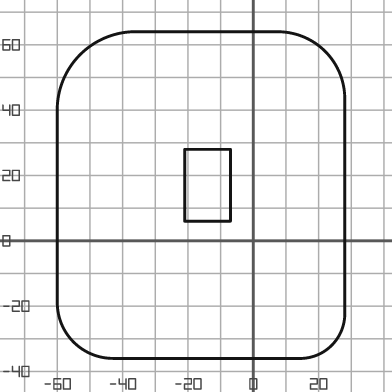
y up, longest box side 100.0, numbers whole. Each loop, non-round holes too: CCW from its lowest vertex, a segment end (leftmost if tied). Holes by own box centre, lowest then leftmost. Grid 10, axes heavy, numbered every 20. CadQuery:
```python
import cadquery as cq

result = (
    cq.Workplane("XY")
    .moveTo(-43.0, -36.0)
    .lineTo(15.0, -36.0)
    .threePointArc((24.0, -32.0), (28.0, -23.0))
    .lineTo(28.0, 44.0)
    .threePointArc((22.0, 58.0), (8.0, 64.0))
    .lineTo(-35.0, 64.0)
    .threePointArc((-53.0, 57.0), (-60.0, 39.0))
    .lineTo(-60.0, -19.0)
    .threePointArc((-55.0, -31.0), (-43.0, -36.0))
    .close()
    .moveTo(-21.0, 6.0)
    .lineTo(-7.0, 6.0)
    .lineTo(-7.0, 28.0)
    .lineTo(-21.0, 28.0)
    .close()
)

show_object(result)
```